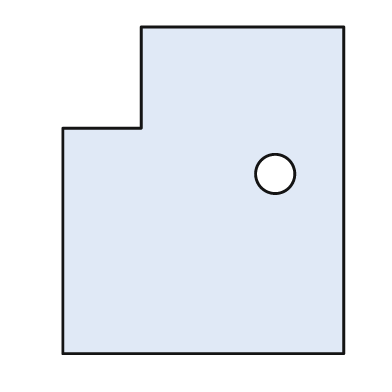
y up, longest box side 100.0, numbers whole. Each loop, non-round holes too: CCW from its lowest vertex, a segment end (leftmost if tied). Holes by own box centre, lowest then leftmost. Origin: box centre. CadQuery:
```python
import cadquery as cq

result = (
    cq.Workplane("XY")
    .moveTo(-43.0, -50.0)
    .lineTo(43.0, -50.0)
    .lineTo(43.0, 50.0)
    .lineTo(-19.0, 50.0)
    .lineTo(-19.0, 19.0)
    .lineTo(-43.0, 19.0)
    .close()
    .moveTo(22.0, 5.0)
    .circle(6.0)
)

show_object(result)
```